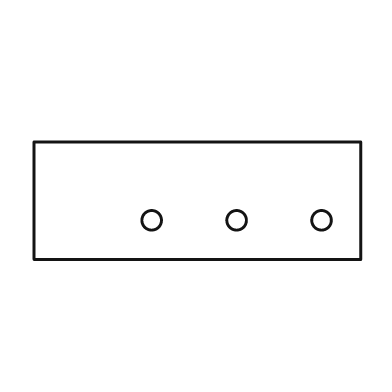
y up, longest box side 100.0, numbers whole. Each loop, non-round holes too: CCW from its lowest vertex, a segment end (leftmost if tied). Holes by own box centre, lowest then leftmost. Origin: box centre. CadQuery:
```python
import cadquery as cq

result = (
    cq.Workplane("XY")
    .moveTo(-50.0, -18.0)
    .lineTo(50.0, -18.0)
    .lineTo(50.0, 18.0)
    .lineTo(-50.0, 18.0)
    .close()
    .moveTo(-14.0, -6.0)
    .circle(3.0)
    .moveTo(12.0, -6.0)
    .circle(3.0)
    .moveTo(38.0, -6.0)
    .circle(3.0)
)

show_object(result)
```